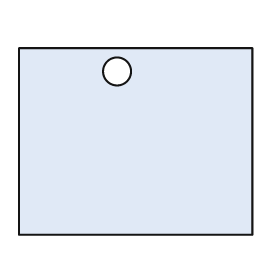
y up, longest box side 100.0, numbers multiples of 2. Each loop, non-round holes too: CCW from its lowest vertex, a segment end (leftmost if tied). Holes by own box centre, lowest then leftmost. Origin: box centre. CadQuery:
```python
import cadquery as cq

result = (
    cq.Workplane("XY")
    .moveTo(-50.0, -40.0)
    .lineTo(50.0, -40.0)
    .lineTo(50.0, 40.0)
    .lineTo(-50.0, 40.0)
    .close()
    .moveTo(-8.0, 30.0)
    .circle(6.0)
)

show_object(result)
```